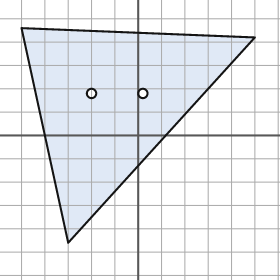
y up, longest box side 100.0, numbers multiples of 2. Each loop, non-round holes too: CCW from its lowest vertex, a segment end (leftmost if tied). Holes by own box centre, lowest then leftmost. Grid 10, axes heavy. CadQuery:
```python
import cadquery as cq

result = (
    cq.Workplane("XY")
    .moveTo(-30.0, -46.0)
    .lineTo(50.0, 42.0)
    .lineTo(-50.0, 46.0)
    .close()
    .moveTo(-20.0, 18.0)
    .circle(2.0)
    .moveTo(2.0, 18.0)
    .circle(2.0)
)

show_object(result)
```